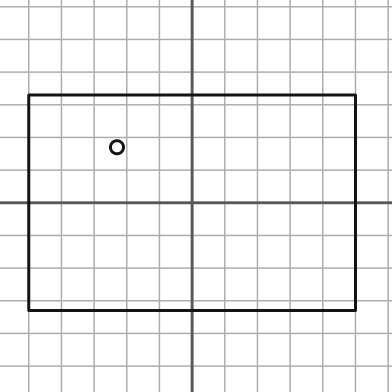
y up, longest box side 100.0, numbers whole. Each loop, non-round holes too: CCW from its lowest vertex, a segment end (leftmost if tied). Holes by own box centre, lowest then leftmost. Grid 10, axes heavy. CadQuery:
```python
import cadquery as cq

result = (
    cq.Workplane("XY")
    .moveTo(-50.0, -33.0)
    .lineTo(50.0, -33.0)
    .lineTo(50.0, 33.0)
    .lineTo(-50.0, 33.0)
    .close()
    .moveTo(-23.0, 17.0)
    .circle(2.0)
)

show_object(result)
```